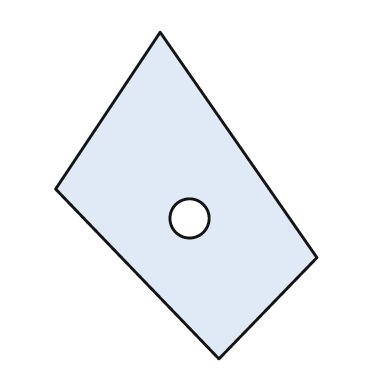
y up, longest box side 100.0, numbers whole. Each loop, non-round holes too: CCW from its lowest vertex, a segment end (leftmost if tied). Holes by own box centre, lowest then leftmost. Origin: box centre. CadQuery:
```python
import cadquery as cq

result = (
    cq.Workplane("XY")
    .moveTo(10.0, -50.0)
    .lineTo(40.0, -19.0)
    .lineTo(-8.0, 50.0)
    .lineTo(-40.0, 2.0)
    .close()
    .moveTo(1.0, -7.0)
    .circle(6.0)
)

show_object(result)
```